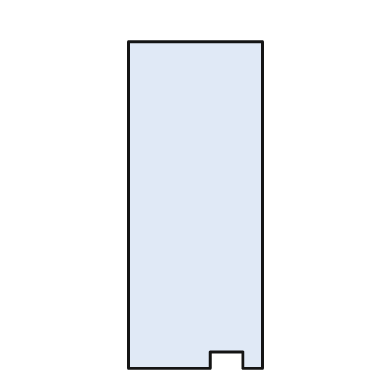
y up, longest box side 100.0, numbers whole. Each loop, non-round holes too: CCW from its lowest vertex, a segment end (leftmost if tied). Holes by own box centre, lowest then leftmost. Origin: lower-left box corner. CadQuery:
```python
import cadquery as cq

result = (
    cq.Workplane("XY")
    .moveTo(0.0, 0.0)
    .lineTo(25.0, 0.0)
    .lineTo(25.0, 5.0)
    .lineTo(35.0, 5.0)
    .lineTo(35.0, 0.0)
    .lineTo(41.0, 0.0)
    .lineTo(41.0, 100.0)
    .lineTo(0.0, 100.0)
    .close()
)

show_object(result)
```